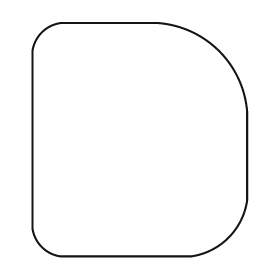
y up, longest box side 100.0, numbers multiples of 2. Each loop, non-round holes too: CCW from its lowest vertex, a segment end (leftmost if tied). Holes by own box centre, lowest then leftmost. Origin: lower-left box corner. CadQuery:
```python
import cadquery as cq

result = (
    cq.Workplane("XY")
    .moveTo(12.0, 0.0)
    .lineTo(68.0, 0.0)
    .threePointArc((84.0, 8.0), (92.0, 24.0))
    .lineTo(92.0, 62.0)
    .threePointArc((80.0, 88.0), (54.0, 100.0))
    .lineTo(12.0, 100.0)
    .threePointArc((4.0, 96.0), (0.0, 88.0))
    .lineTo(0.0, 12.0)
    .threePointArc((4.0, 4.0), (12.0, 0.0))
    .close()
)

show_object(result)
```